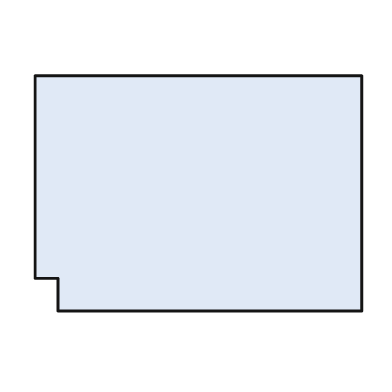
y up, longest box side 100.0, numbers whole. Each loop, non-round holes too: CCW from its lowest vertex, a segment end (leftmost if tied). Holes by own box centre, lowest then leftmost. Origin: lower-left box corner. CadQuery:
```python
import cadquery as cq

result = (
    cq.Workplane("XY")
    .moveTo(7.0, 0.0)
    .lineTo(100.0, 0.0)
    .lineTo(100.0, 72.0)
    .lineTo(0.0, 72.0)
    .lineTo(0.0, 10.0)
    .lineTo(7.0, 10.0)
    .close()
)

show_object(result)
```